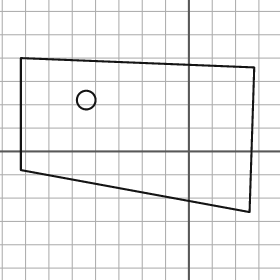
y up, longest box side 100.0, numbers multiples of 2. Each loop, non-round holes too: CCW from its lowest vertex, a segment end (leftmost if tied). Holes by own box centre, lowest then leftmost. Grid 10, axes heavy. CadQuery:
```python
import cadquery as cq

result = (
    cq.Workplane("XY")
    .moveTo(26.0, -26.0)
    .lineTo(28.0, 36.0)
    .lineTo(-72.0, 40.0)
    .lineTo(-72.0, -8.0)
    .close()
    .moveTo(-44.0, 22.0)
    .circle(4.0)
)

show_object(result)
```